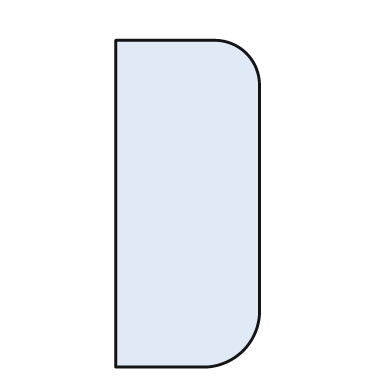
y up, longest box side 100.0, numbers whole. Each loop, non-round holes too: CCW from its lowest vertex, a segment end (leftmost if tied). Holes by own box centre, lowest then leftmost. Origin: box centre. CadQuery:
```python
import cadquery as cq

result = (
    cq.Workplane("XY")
    .moveTo(-22.0, -50.0)
    .lineTo(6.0, -50.0)
    .threePointArc((17.0, -45.0), (22.0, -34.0))
    .lineTo(22.0, 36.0)
    .threePointArc((18.0, 46.0), (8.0, 50.0))
    .lineTo(-22.0, 50.0)
    .close()
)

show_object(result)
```